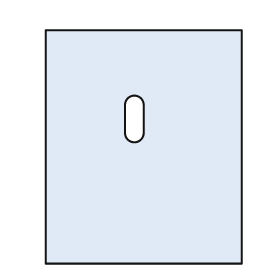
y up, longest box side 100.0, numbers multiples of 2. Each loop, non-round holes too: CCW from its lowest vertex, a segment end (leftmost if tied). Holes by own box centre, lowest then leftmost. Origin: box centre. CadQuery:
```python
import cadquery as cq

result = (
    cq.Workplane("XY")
    .moveTo(-42.0, -50.0)
    .lineTo(42.0, -50.0)
    .lineTo(42.0, 50.0)
    .lineTo(-42.0, 50.0)
    .close()
    .moveTo(-8.0, 6.0)
    .threePointArc((-4.0, 2.0), (0.0, 6.0))
    .lineTo(0.0, 18.0)
    .threePointArc((-4.0, 22.0), (-8.0, 18.0))
    .close()
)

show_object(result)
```